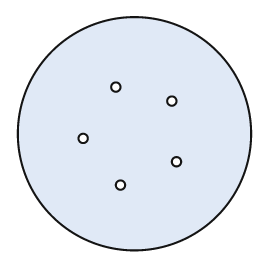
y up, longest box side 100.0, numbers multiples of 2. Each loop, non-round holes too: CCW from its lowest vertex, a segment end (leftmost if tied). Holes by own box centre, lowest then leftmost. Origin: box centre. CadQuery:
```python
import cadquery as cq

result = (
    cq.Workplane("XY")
    .moveTo(0.0, 0.0)
    .circle(50.0)
    .moveTo(-6.0, -22.0)
    .circle(2.0)
    .moveTo(18.0, -12.0)
    .circle(2.0)
    .moveTo(-22.0, -2.0)
    .circle(2.0)
    .moveTo(16.0, 14.0)
    .circle(2.0)
    .moveTo(-8.0, 20.0)
    .circle(2.0)
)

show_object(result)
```